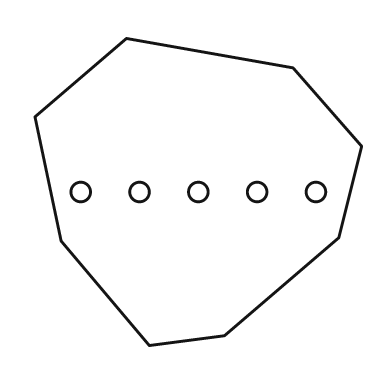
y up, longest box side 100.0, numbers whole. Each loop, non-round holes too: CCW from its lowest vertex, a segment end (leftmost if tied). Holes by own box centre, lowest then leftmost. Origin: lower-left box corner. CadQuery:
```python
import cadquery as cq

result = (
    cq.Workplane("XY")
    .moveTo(35.0, 0.0)
    .lineTo(58.0, 3.0)
    .lineTo(93.0, 33.0)
    .lineTo(100.0, 61.0)
    .lineTo(79.0, 85.0)
    .lineTo(28.0, 94.0)
    .lineTo(0.0, 70.0)
    .lineTo(8.0, 32.0)
    .close()
    .moveTo(14.0, 47.0)
    .circle(3.0)
    .moveTo(32.0, 47.0)
    .circle(3.0)
    .moveTo(50.0, 47.0)
    .circle(3.0)
    .moveTo(68.0, 47.0)
    .circle(3.0)
    .moveTo(86.0, 47.0)
    .circle(3.0)
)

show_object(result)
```